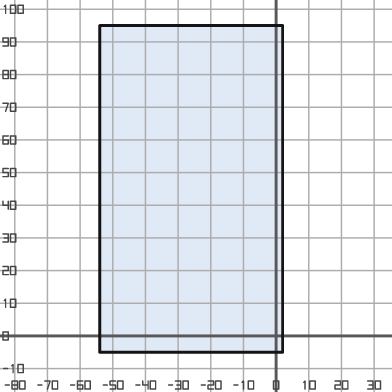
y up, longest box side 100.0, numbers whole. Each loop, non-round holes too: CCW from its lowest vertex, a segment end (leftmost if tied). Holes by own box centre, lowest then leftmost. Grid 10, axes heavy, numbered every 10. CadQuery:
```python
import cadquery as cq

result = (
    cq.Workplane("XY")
    .moveTo(-54.0, -5.0)
    .lineTo(2.0, -5.0)
    .lineTo(2.0, 95.0)
    .lineTo(-54.0, 95.0)
    .close()
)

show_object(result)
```